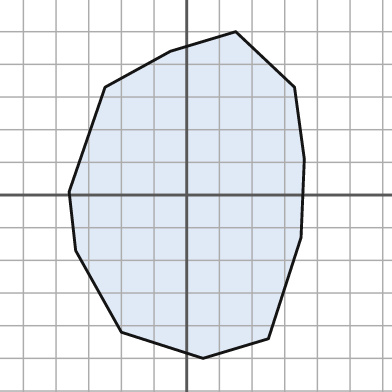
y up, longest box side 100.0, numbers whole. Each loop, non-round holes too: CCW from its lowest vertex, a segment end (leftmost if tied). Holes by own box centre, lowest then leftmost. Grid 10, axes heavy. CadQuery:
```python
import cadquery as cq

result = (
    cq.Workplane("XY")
    .moveTo(5.0, -50.0)
    .lineTo(25.0, -44.0)
    .lineTo(35.0, -13.0)
    .lineTo(36.0, 11.0)
    .lineTo(33.0, 33.0)
    .lineTo(15.0, 50.0)
    .lineTo(-5.0, 44.0)
    .lineTo(-25.0, 33.0)
    .lineTo(-36.0, 1.0)
    .lineTo(-34.0, -17.0)
    .lineTo(-20.0, -42.0)
    .close()
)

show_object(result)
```